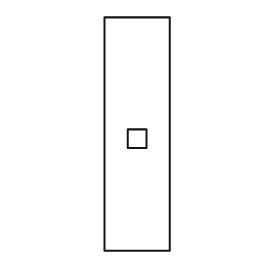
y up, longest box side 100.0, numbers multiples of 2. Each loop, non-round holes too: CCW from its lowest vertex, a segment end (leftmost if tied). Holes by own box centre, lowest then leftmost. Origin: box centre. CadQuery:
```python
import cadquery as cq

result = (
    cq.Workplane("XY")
    .moveTo(-14.0, -50.0)
    .lineTo(14.0, -50.0)
    .lineTo(14.0, 50.0)
    .lineTo(-14.0, 50.0)
    .close()
    .moveTo(-4.0, -6.0)
    .lineTo(4.0, -6.0)
    .lineTo(4.0, 2.0)
    .lineTo(-4.0, 2.0)
    .close()
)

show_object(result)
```